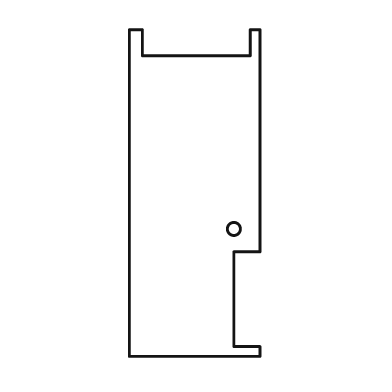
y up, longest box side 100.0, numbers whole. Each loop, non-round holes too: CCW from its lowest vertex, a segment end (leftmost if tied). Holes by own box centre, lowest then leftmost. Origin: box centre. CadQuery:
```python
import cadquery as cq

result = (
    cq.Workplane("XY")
    .moveTo(-20.0, -50.0)
    .lineTo(20.0, -50.0)
    .lineTo(20.0, -47.0)
    .lineTo(12.0, -47.0)
    .lineTo(12.0, -18.0)
    .lineTo(20.0, -18.0)
    .lineTo(20.0, 50.0)
    .lineTo(17.0, 50.0)
    .lineTo(17.0, 42.0)
    .lineTo(-16.0, 42.0)
    .lineTo(-16.0, 50.0)
    .lineTo(-20.0, 50.0)
    .close()
    .moveTo(12.0, -11.0)
    .circle(2.0)
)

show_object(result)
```